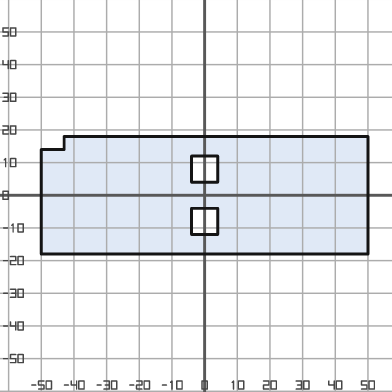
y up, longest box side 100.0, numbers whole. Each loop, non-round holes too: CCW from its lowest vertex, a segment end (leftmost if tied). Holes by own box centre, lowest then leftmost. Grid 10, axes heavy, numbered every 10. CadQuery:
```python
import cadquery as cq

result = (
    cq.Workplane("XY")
    .moveTo(-50.0, -18.0)
    .lineTo(50.0, -18.0)
    .lineTo(50.0, 18.0)
    .lineTo(-43.0, 18.0)
    .lineTo(-43.0, 14.0)
    .lineTo(-50.0, 14.0)
    .close()
    .moveTo(-4.0, -12.0)
    .lineTo(4.0, -12.0)
    .lineTo(4.0, -4.0)
    .lineTo(-4.0, -4.0)
    .close()
    .moveTo(-4.0, 4.0)
    .lineTo(4.0, 4.0)
    .lineTo(4.0, 12.0)
    .lineTo(-4.0, 12.0)
    .close()
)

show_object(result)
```